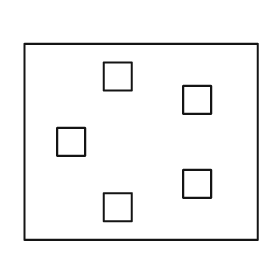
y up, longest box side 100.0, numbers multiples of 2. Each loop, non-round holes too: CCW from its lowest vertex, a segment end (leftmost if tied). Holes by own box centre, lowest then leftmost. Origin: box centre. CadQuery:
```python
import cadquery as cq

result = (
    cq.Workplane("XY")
    .moveTo(-50.0, -42.0)
    .lineTo(50.0, -42.0)
    .lineTo(50.0, 42.0)
    .lineTo(-50.0, 42.0)
    .close()
    .moveTo(-16.0, -34.0)
    .lineTo(-4.0, -34.0)
    .lineTo(-4.0, -22.0)
    .lineTo(-16.0, -22.0)
    .close()
    .moveTo(18.0, -24.0)
    .lineTo(30.0, -24.0)
    .lineTo(30.0, -12.0)
    .lineTo(18.0, -12.0)
    .close()
    .moveTo(-36.0, -6.0)
    .lineTo(-24.0, -6.0)
    .lineTo(-24.0, 6.0)
    .lineTo(-36.0, 6.0)
    .close()
    .moveTo(18.0, 12.0)
    .lineTo(30.0, 12.0)
    .lineTo(30.0, 24.0)
    .lineTo(18.0, 24.0)
    .close()
    .moveTo(-16.0, 22.0)
    .lineTo(-4.0, 22.0)
    .lineTo(-4.0, 34.0)
    .lineTo(-16.0, 34.0)
    .close()
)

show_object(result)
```